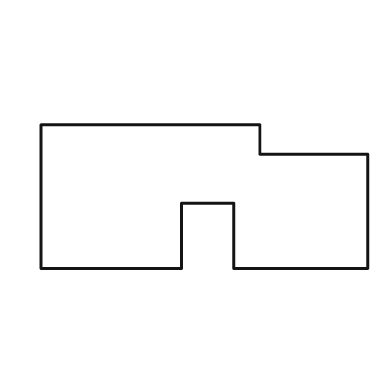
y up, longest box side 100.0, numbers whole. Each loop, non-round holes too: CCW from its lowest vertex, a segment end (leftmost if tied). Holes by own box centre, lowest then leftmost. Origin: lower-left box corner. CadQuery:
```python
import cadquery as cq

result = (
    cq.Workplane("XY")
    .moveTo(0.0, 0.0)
    .lineTo(43.0, 0.0)
    .lineTo(43.0, 20.0)
    .lineTo(59.0, 20.0)
    .lineTo(59.0, 0.0)
    .lineTo(100.0, 0.0)
    .lineTo(100.0, 35.0)
    .lineTo(67.0, 35.0)
    .lineTo(67.0, 44.0)
    .lineTo(0.0, 44.0)
    .close()
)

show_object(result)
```